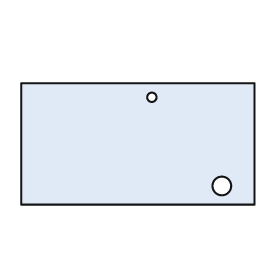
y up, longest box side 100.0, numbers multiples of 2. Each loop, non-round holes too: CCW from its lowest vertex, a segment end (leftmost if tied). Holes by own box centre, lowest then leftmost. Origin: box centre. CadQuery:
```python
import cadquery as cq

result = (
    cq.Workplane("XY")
    .moveTo(-50.0, -26.0)
    .lineTo(50.0, -26.0)
    .lineTo(50.0, 26.0)
    .lineTo(-50.0, 26.0)
    .close()
    .moveTo(36.0, -18.0)
    .circle(4.0)
    .moveTo(6.0, 20.0)
    .circle(2.0)
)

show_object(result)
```